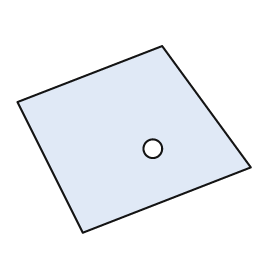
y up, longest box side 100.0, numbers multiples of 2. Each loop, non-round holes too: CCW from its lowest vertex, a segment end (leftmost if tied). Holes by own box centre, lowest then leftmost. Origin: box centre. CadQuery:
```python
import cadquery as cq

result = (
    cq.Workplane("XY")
    .moveTo(-22.0, -40.0)
    .lineTo(50.0, -12.0)
    .lineTo(12.0, 40.0)
    .lineTo(-50.0, 16.0)
    .close()
    .moveTo(8.0, -4.0)
    .circle(4.0)
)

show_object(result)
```